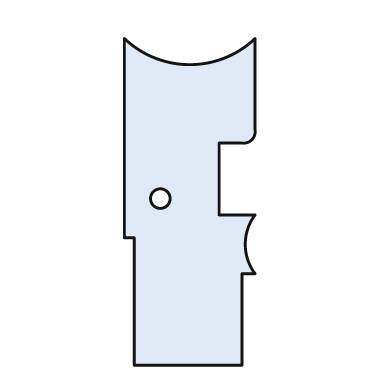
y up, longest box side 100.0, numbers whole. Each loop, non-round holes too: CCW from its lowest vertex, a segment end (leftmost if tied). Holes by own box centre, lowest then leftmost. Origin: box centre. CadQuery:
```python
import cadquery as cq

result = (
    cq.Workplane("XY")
    .moveTo(-17.0, -50.0)
    .lineTo(16.0, -50.0)
    .lineTo(16.0, -22.0)
    .lineTo(20.0, -22.0)
    .threePointArc((17.0, -13.0), (20.0, -4.0))
    .lineTo(9.0, -4.0)
    .lineTo(9.0, 18.0)
    .lineTo(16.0, 18.0)
    .threePointArc((19.0, 19.0), (20.0, 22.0))
    .lineTo(20.0, 50.0)
    .threePointArc((0.0, 42.0), (-20.0, 50.0))
    .lineTo(-20.0, -11.0)
    .lineTo(-17.0, -11.0)
    .close()
    .moveTo(-9.0, 1.0)
    .circle(3.0)
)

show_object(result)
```